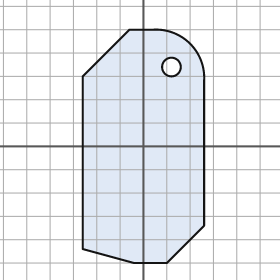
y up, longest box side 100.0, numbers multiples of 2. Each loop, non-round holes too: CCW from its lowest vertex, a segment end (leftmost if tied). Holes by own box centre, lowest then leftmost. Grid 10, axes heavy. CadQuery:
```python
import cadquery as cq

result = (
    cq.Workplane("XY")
    .moveTo(-4.0, -50.0)
    .lineTo(10.0, -50.0)
    .lineTo(26.0, -34.0)
    .lineTo(26.0, 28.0)
    .threePointArc((20.0, 44.0), (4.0, 50.0))
    .lineTo(-6.0, 50.0)
    .lineTo(-26.0, 30.0)
    .lineTo(-26.0, -44.0)
    .close()
    .moveTo(12.0, 34.0)
    .circle(4.0)
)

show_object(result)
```